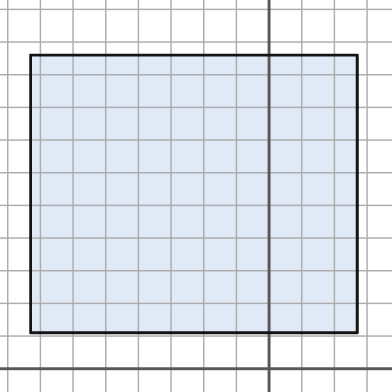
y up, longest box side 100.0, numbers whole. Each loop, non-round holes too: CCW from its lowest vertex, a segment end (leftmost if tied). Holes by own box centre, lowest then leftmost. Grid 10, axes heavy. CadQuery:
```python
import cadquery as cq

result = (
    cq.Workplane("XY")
    .moveTo(-73.0, 11.0)
    .lineTo(27.0, 11.0)
    .lineTo(27.0, 96.0)
    .lineTo(-73.0, 96.0)
    .close()
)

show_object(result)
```